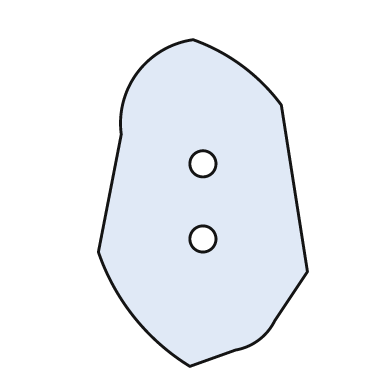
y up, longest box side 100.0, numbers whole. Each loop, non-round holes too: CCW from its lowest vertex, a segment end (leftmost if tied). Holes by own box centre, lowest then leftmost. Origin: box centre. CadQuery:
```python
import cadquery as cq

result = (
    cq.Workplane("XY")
    .moveTo(-4.0, -50.0)
    .lineTo(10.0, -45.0)
    .threePointArc((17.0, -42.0), (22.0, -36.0))
    .lineTo(32.0, -21.0)
    .lineTo(24.0, 30.0)
    .threePointArc((12.0, 42.0), (-3.0, 50.0))
    .threePointArc((-20.0, 40.0), (-25.0, 21.0))
    .lineTo(-32.0, -15.0)
    .threePointArc((-21.0, -35.0), (-4.0, -50.0))
    .close()
    .moveTo(0.0, -11.0)
    .circle(4.0)
    .moveTo(0.0, 12.0)
    .circle(4.0)
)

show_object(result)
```